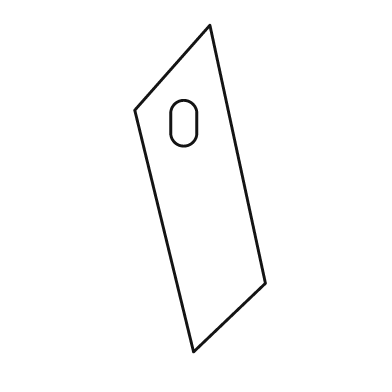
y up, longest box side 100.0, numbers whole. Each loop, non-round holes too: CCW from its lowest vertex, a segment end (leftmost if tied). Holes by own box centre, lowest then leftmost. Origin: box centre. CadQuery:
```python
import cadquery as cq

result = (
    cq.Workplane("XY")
    .moveTo(-2.0, -50.0)
    .lineTo(20.0, -29.0)
    .lineTo(3.0, 50.0)
    .lineTo(-20.0, 24.0)
    .close()
    .moveTo(-9.0, 17.0)
    .threePointArc((-5.0, 13.0), (-1.0, 17.0))
    .lineTo(-1.0, 23.0)
    .threePointArc((-5.0, 27.0), (-9.0, 23.0))
    .close()
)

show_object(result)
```